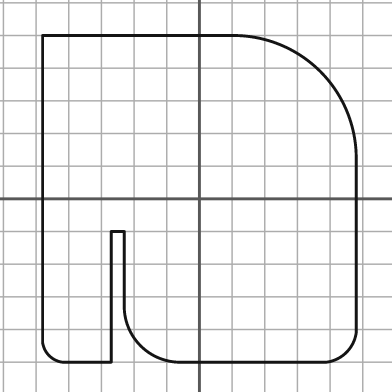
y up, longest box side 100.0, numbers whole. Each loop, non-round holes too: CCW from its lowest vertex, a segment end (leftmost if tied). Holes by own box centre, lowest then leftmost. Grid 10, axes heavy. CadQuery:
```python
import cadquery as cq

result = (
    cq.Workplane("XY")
    .moveTo(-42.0, -50.0)
    .lineTo(-27.0, -50.0)
    .lineTo(-27.0, -10.0)
    .lineTo(-23.0, -10.0)
    .lineTo(-23.0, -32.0)
    .threePointArc((-18.0, -45.0), (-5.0, -50.0))
    .lineTo(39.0, -50.0)
    .threePointArc((45.0, -47.0), (48.0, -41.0))
    .lineTo(48.0, 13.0)
    .threePointArc((37.0, 39.0), (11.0, 50.0))
    .lineTo(-48.0, 50.0)
    .lineTo(-48.0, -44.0)
    .threePointArc((-46.0, -48.0), (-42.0, -50.0))
    .close()
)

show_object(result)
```